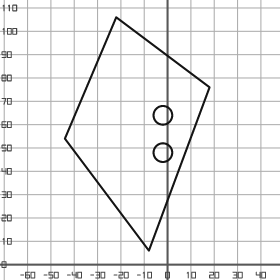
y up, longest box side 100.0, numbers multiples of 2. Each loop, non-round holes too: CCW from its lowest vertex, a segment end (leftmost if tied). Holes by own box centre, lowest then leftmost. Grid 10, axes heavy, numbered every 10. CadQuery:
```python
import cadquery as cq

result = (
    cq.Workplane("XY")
    .moveTo(-8.0, 6.0)
    .lineTo(18.0, 76.0)
    .lineTo(-22.0, 106.0)
    .lineTo(-44.0, 54.0)
    .close()
    .moveTo(-2.0, 48.0)
    .circle(4.0)
    .moveTo(-2.0, 64.0)
    .circle(4.0)
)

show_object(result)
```